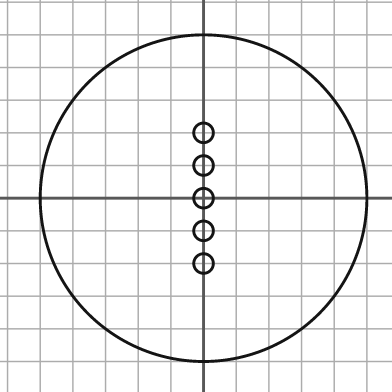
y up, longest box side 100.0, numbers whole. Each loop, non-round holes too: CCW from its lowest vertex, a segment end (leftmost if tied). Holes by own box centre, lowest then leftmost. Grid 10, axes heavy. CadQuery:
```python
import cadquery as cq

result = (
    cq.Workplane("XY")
    .moveTo(0.0, 0.0)
    .circle(50.0)
    .moveTo(0.0, -20.0)
    .circle(3.0)
    .moveTo(0.0, -10.0)
    .circle(3.0)
    .moveTo(0.0, 0.0)
    .circle(3.0)
    .moveTo(0.0, 10.0)
    .circle(3.0)
    .moveTo(0.0, 20.0)
    .circle(3.0)
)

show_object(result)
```